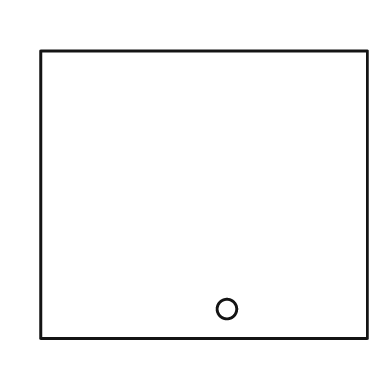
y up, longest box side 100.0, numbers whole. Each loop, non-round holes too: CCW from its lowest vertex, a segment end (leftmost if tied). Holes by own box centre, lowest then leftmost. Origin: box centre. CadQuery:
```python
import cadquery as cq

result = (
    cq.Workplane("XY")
    .moveTo(-50.0, -44.0)
    .lineTo(50.0, -44.0)
    .lineTo(50.0, 44.0)
    .lineTo(-50.0, 44.0)
    .close()
    .moveTo(7.0, -35.0)
    .circle(3.0)
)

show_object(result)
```